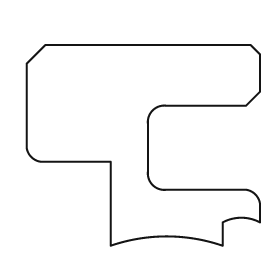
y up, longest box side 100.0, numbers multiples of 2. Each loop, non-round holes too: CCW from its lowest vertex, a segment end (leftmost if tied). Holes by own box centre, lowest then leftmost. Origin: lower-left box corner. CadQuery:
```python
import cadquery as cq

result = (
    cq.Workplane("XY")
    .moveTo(36.0, 0.0)
    .threePointArc((60.0, 4.0), (84.0, 0.0))
    .lineTo(84.0, 10.0)
    .threePointArc((92.0, 12.0), (100.0, 10.0))
    .lineTo(100.0, 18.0)
    .threePointArc((98.0, 22.0), (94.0, 24.0))
    .lineTo(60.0, 24.0)
    .threePointArc((54.0, 26.0), (52.0, 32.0))
    .lineTo(52.0, 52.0)
    .threePointArc((54.0, 58.0), (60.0, 60.0))
    .lineTo(94.0, 60.0)
    .lineTo(100.0, 66.0)
    .lineTo(100.0, 82.0)
    .lineTo(96.0, 86.0)
    .lineTo(8.0, 86.0)
    .lineTo(0.0, 78.0)
    .lineTo(0.0, 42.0)
    .threePointArc((2.0, 38.0), (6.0, 36.0))
    .lineTo(36.0, 36.0)
    .close()
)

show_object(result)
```